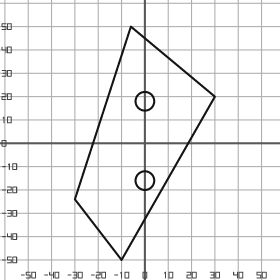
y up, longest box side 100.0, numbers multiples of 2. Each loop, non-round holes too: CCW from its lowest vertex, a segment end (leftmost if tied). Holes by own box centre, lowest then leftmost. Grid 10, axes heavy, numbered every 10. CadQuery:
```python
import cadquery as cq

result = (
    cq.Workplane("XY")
    .moveTo(-10.0, -50.0)
    .lineTo(30.0, 20.0)
    .lineTo(-6.0, 50.0)
    .lineTo(-30.0, -24.0)
    .close()
    .moveTo(0.0, -16.0)
    .circle(4.0)
    .moveTo(0.0, 18.0)
    .circle(4.0)
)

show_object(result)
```